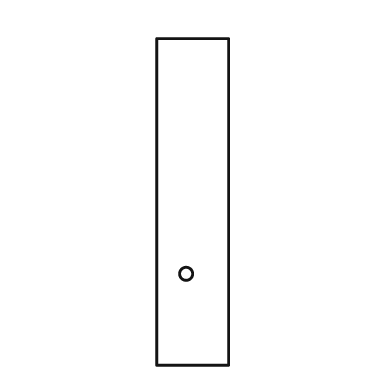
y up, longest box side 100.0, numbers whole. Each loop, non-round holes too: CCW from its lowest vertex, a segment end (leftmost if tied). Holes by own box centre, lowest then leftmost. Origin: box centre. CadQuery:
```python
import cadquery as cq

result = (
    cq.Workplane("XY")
    .moveTo(-11.0, -50.0)
    .lineTo(11.0, -50.0)
    .lineTo(11.0, 50.0)
    .lineTo(-11.0, 50.0)
    .close()
    .moveTo(-2.0, -22.0)
    .circle(2.0)
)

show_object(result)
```